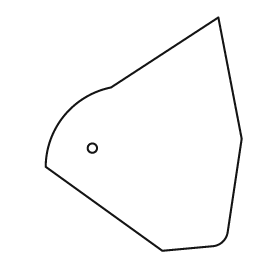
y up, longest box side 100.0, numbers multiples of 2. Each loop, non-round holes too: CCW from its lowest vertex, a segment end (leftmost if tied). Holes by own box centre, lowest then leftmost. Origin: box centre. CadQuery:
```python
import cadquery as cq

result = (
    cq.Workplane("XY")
    .moveTo(8.0, -50.0)
    .lineTo(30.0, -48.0)
    .threePointArc((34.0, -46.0), (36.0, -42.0))
    .lineTo(42.0, -2.0)
    .lineTo(32.0, 50.0)
    .lineTo(-14.0, 20.0)
    .threePointArc((-34.0, 8.0), (-42.0, -14.0))
    .close()
    .moveTo(-22.0, -6.0)
    .circle(2.0)
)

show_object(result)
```